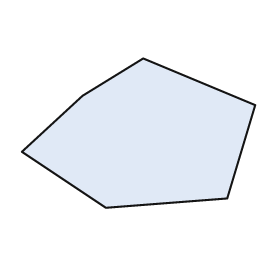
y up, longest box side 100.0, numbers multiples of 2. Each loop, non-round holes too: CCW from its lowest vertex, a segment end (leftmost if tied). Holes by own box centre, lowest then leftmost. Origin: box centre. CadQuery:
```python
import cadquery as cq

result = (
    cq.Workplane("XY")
    .moveTo(-14.0, -32.0)
    .lineTo(38.0, -28.0)
    .lineTo(50.0, 12.0)
    .lineTo(2.0, 32.0)
    .lineTo(-24.0, 16.0)
    .lineTo(-50.0, -8.0)
    .close()
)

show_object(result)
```